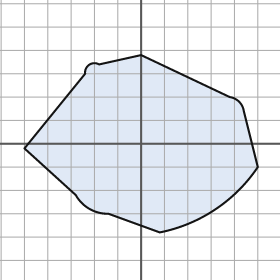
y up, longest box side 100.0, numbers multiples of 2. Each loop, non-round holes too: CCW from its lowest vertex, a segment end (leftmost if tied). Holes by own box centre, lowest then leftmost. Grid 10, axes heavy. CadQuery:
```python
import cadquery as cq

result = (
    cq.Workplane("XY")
    .moveTo(8.0, -38.0)
    .threePointArc((32.0, -28.0), (50.0, -10.0))
    .lineTo(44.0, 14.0)
    .threePointArc((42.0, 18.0), (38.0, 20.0))
    .lineTo(0.0, 38.0)
    .lineTo(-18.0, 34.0)
    .threePointArc((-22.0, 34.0), (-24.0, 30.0))
    .lineTo(-50.0, -2.0)
    .lineTo(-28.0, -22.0)
    .threePointArc((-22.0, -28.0), (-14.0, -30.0))
    .close()
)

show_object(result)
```